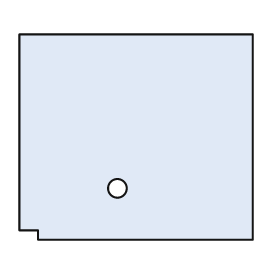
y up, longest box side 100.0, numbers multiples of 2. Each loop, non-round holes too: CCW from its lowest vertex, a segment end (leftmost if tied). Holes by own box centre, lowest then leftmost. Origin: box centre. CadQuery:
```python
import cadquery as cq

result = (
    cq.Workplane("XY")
    .moveTo(-42.0, -44.0)
    .lineTo(50.0, -44.0)
    .lineTo(50.0, 44.0)
    .lineTo(-50.0, 44.0)
    .lineTo(-50.0, -40.0)
    .lineTo(-42.0, -40.0)
    .close()
    .moveTo(-8.0, -22.0)
    .circle(4.0)
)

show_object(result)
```